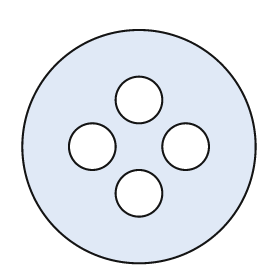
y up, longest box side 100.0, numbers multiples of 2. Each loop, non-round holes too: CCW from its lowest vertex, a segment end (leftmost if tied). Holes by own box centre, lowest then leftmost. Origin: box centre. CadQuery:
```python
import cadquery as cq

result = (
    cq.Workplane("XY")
    .moveTo(0.0, 0.0)
    .circle(50.0)
    .moveTo(0.0, -20.0)
    .circle(10.0)
    .moveTo(-20.0, 0.0)
    .circle(10.0)
    .moveTo(20.0, 0.0)
    .circle(10.0)
    .moveTo(0.0, 20.0)
    .circle(10.0)
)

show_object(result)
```